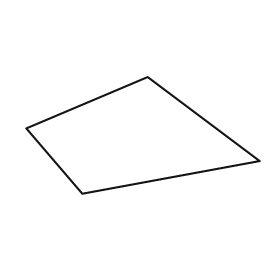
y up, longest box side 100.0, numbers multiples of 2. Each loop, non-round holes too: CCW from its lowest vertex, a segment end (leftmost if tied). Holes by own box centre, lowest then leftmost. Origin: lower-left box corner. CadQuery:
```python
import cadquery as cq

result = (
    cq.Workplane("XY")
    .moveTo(24.0, 0.0)
    .lineTo(100.0, 14.0)
    .lineTo(52.0, 50.0)
    .lineTo(0.0, 28.0)
    .close()
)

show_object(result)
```